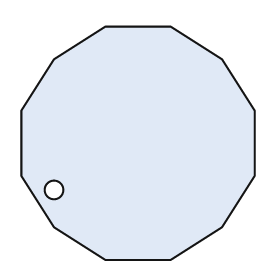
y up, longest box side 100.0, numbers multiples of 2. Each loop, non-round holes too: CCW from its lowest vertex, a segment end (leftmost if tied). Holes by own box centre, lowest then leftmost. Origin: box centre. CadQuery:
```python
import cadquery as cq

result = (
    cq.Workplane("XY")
    .moveTo(-14.0, -50.0)
    .lineTo(14.0, -50.0)
    .lineTo(36.0, -36.0)
    .lineTo(50.0, -14.0)
    .lineTo(50.0, 14.0)
    .lineTo(36.0, 36.0)
    .lineTo(14.0, 50.0)
    .lineTo(-14.0, 50.0)
    .lineTo(-36.0, 36.0)
    .lineTo(-50.0, 14.0)
    .lineTo(-50.0, -14.0)
    .lineTo(-36.0, -36.0)
    .close()
    .moveTo(-36.0, -20.0)
    .circle(4.0)
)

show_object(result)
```